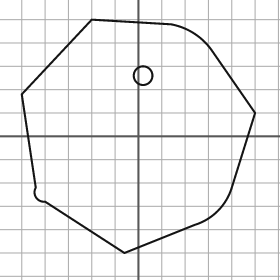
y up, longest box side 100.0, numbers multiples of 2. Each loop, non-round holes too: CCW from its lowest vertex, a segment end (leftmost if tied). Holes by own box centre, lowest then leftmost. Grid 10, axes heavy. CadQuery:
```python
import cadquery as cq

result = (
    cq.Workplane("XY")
    .moveTo(-6.0, -50.0)
    .lineTo(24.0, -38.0)
    .threePointArc((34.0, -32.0), (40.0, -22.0))
    .lineTo(50.0, 10.0)
    .lineTo(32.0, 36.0)
    .threePointArc((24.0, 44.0), (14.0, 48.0))
    .lineTo(-20.0, 50.0)
    .lineTo(-50.0, 18.0)
    .lineTo(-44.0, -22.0)
    .threePointArc((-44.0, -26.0), (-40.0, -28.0))
    .close()
    .moveTo(2.0, 26.0)
    .circle(4.0)
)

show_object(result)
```